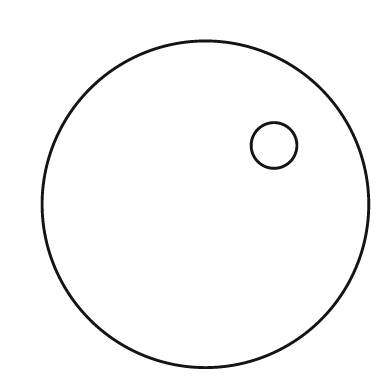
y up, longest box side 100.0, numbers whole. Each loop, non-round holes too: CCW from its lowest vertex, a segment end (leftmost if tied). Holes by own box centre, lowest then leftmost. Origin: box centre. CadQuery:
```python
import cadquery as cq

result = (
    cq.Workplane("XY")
    .moveTo(0.0, 0.0)
    .circle(50.0)
    .moveTo(21.0, 18.0)
    .circle(7.0)
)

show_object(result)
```